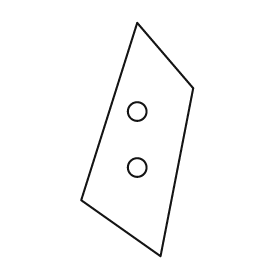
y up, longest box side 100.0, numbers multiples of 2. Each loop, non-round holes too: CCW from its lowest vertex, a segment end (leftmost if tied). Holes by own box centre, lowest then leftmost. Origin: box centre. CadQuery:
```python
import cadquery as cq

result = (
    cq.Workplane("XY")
    .moveTo(10.0, -50.0)
    .lineTo(24.0, 22.0)
    .lineTo(0.0, 50.0)
    .lineTo(-24.0, -26.0)
    .close()
    .moveTo(0.0, -12.0)
    .circle(4.0)
    .moveTo(0.0, 12.0)
    .circle(4.0)
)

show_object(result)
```